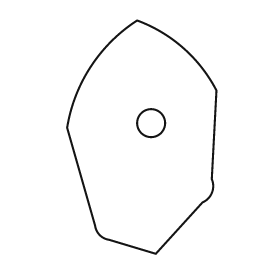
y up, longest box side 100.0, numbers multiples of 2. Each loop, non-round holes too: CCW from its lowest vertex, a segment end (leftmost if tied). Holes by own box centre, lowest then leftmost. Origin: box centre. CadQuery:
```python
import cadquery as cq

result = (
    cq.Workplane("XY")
    .moveTo(6.0, -50.0)
    .lineTo(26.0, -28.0)
    .threePointArc((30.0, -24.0), (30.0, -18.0))
    .lineTo(32.0, 20.0)
    .threePointArc((18.0, 38.0), (-2.0, 50.0))
    .threePointArc((-22.0, 30.0), (-32.0, 4.0))
    .lineTo(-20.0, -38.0)
    .threePointArc((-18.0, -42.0), (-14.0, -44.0))
    .close()
    .moveTo(4.0, 6.0)
    .circle(6.0)
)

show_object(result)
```